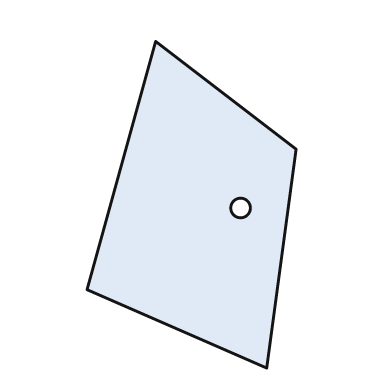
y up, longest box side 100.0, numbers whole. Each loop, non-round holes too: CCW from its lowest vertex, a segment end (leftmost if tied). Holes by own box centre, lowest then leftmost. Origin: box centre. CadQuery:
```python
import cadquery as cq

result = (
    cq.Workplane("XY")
    .moveTo(23.0, -50.0)
    .lineTo(32.0, 17.0)
    .lineTo(-11.0, 50.0)
    .lineTo(-32.0, -26.0)
    .close()
    .moveTo(15.0, -1.0)
    .circle(3.0)
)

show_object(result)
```